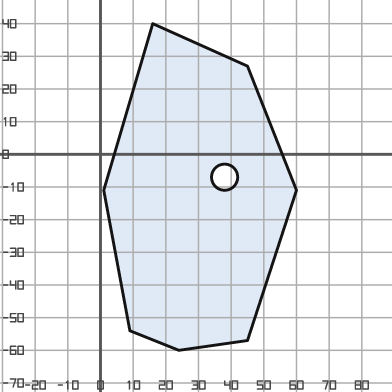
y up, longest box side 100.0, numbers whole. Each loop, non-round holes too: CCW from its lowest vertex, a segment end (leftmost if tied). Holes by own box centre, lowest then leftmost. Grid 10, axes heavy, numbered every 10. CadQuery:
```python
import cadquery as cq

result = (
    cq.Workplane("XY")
    .moveTo(24.0, -60.0)
    .lineTo(45.0, -57.0)
    .lineTo(60.0, -11.0)
    .lineTo(45.0, 27.0)
    .lineTo(16.0, 40.0)
    .lineTo(1.0, -11.0)
    .lineTo(9.0, -54.0)
    .close()
    .moveTo(38.0, -7.0)
    .circle(4.0)
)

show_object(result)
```